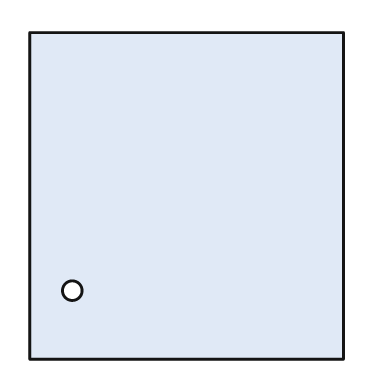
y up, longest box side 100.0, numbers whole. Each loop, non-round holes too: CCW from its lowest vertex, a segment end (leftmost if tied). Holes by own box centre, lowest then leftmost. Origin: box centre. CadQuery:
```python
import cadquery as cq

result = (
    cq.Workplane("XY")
    .moveTo(-48.0, -50.0)
    .lineTo(48.0, -50.0)
    .lineTo(48.0, 50.0)
    .lineTo(-48.0, 50.0)
    .close()
    .moveTo(-35.0, -29.0)
    .circle(3.0)
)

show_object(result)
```